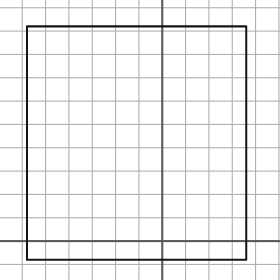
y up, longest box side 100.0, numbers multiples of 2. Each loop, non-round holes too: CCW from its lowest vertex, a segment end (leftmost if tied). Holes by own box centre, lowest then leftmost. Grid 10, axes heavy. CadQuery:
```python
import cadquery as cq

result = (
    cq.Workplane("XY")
    .moveTo(-58.0, -8.0)
    .lineTo(36.0, -8.0)
    .lineTo(36.0, 92.0)
    .lineTo(-58.0, 92.0)
    .close()
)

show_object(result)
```